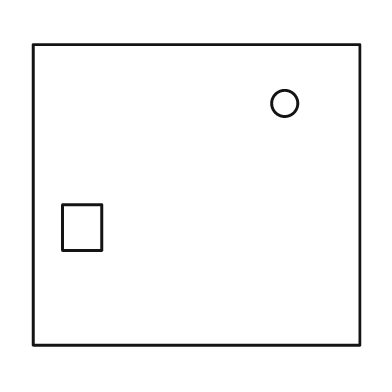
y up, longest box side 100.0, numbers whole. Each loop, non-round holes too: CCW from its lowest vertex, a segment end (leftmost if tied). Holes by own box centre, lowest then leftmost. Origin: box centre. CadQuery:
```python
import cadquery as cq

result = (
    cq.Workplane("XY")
    .moveTo(-50.0, -46.0)
    .lineTo(50.0, -46.0)
    .lineTo(50.0, 46.0)
    .lineTo(-50.0, 46.0)
    .close()
    .moveTo(-41.0, -17.0)
    .lineTo(-29.0, -17.0)
    .lineTo(-29.0, -3.0)
    .lineTo(-41.0, -3.0)
    .close()
    .moveTo(27.0, 28.0)
    .circle(4.0)
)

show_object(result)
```